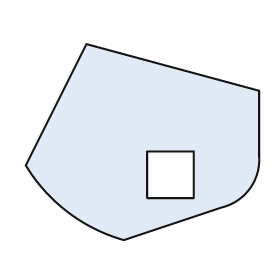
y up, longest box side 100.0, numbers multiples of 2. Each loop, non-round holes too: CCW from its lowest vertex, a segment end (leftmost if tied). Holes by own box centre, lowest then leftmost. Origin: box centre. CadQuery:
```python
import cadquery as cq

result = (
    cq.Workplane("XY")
    .moveTo(-8.0, -42.0)
    .lineTo(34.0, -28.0)
    .threePointArc((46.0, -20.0), (50.0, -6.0))
    .lineTo(50.0, 22.0)
    .lineTo(-24.0, 42.0)
    .lineTo(-50.0, -10.0)
    .threePointArc((-32.0, -30.0), (-8.0, -42.0))
    .close()
    .moveTo(2.0, -24.0)
    .lineTo(22.0, -24.0)
    .lineTo(22.0, -4.0)
    .lineTo(2.0, -4.0)
    .close()
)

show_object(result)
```